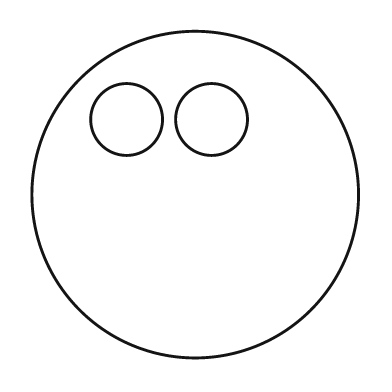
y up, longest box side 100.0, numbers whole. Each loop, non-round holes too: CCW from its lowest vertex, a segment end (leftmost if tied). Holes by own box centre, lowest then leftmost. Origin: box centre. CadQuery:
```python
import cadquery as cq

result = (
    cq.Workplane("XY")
    .moveTo(0.0, 0.0)
    .circle(50.0)
    .moveTo(-21.0, 23.0)
    .circle(11.0)
    .moveTo(5.0, 23.0)
    .circle(11.0)
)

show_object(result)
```